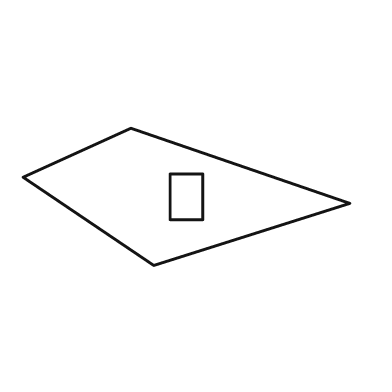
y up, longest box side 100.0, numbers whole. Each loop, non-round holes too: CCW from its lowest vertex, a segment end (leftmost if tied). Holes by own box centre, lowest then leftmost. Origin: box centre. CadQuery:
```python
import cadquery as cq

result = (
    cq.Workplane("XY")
    .moveTo(-10.0, -21.0)
    .lineTo(50.0, -2.0)
    .lineTo(-17.0, 21.0)
    .lineTo(-50.0, 6.0)
    .close()
    .moveTo(-5.0, -7.0)
    .lineTo(5.0, -7.0)
    .lineTo(5.0, 7.0)
    .lineTo(-5.0, 7.0)
    .close()
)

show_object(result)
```